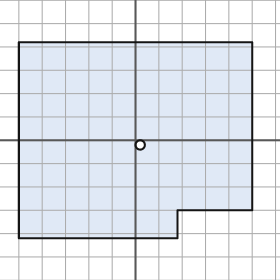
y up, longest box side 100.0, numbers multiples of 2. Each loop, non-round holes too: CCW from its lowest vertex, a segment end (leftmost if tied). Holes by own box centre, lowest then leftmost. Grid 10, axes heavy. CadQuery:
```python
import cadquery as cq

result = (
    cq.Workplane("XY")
    .moveTo(-50.0, -42.0)
    .lineTo(18.0, -42.0)
    .lineTo(18.0, -30.0)
    .lineTo(50.0, -30.0)
    .lineTo(50.0, 42.0)
    .lineTo(-50.0, 42.0)
    .close()
    .moveTo(2.0, -2.0)
    .circle(2.0)
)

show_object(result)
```